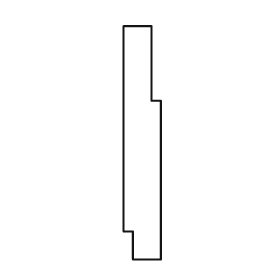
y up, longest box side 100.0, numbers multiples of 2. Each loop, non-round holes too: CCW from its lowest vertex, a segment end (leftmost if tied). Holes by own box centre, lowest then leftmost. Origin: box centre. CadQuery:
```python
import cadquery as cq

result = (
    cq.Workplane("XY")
    .moveTo(-4.0, -50.0)
    .lineTo(8.0, -50.0)
    .lineTo(8.0, 18.0)
    .lineTo(4.0, 18.0)
    .lineTo(4.0, 50.0)
    .lineTo(-8.0, 50.0)
    .lineTo(-8.0, -38.0)
    .lineTo(-4.0, -38.0)
    .close()
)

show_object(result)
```